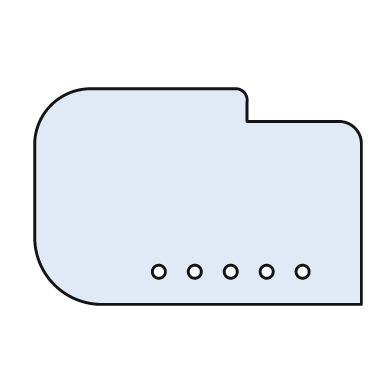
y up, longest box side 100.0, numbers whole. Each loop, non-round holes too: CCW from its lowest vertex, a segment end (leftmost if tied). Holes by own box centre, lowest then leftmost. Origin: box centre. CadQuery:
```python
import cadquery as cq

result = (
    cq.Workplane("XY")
    .moveTo(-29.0, -33.0)
    .lineTo(50.0, -33.0)
    .lineTo(50.0, 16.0)
    .threePointArc((48.0, 21.0), (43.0, 23.0))
    .lineTo(15.0, 23.0)
    .lineTo(15.0, 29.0)
    .threePointArc((14.0, 32.0), (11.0, 33.0))
    .lineTo(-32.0, 33.0)
    .threePointArc((-45.0, 28.0), (-50.0, 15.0))
    .lineTo(-50.0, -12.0)
    .threePointArc((-44.0, -27.0), (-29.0, -33.0))
    .close()
    .moveTo(-12.0, -23.0)
    .circle(2.0)
    .moveTo(-1.0, -23.0)
    .circle(2.0)
    .moveTo(10.0, -23.0)
    .circle(2.0)
    .moveTo(21.0, -23.0)
    .circle(2.0)
    .moveTo(32.0, -23.0)
    .circle(2.0)
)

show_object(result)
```